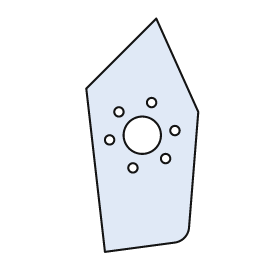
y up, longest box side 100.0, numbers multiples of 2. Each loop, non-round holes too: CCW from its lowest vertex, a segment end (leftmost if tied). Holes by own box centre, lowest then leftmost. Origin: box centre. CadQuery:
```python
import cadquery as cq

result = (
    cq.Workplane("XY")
    .moveTo(-16.0, -50.0)
    .lineTo(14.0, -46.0)
    .threePointArc((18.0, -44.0), (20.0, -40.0))
    .lineTo(24.0, 10.0)
    .lineTo(6.0, 50.0)
    .lineTo(-24.0, 20.0)
    .close()
    .moveTo(-4.0, -14.0)
    .circle(2.0)
    .moveTo(10.0, -10.0)
    .circle(2.0)
    .moveTo(-14.0, -2.0)
    .circle(2.0)
    .moveTo(0.0, 0.0)
    .circle(8.0)
    .moveTo(14.0, 2.0)
    .circle(2.0)
    .moveTo(-10.0, 10.0)
    .circle(2.0)
    .moveTo(4.0, 14.0)
    .circle(2.0)
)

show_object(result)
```